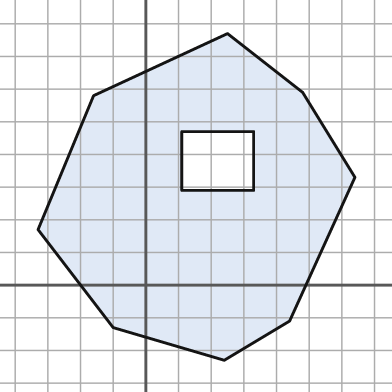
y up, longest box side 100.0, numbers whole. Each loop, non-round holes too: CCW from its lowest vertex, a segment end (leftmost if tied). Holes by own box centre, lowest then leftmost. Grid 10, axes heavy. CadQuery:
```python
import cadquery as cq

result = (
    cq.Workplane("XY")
    .moveTo(24.0, -23.0)
    .lineTo(44.0, -11.0)
    .lineTo(64.0, 33.0)
    .lineTo(48.0, 59.0)
    .lineTo(25.0, 77.0)
    .lineTo(-16.0, 58.0)
    .lineTo(-33.0, 17.0)
    .lineTo(-10.0, -13.0)
    .close()
    .moveTo(11.0, 29.0)
    .lineTo(33.0, 29.0)
    .lineTo(33.0, 47.0)
    .lineTo(11.0, 47.0)
    .close()
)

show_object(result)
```